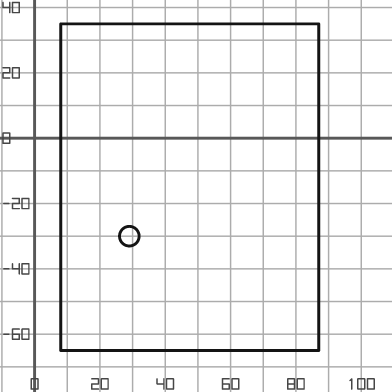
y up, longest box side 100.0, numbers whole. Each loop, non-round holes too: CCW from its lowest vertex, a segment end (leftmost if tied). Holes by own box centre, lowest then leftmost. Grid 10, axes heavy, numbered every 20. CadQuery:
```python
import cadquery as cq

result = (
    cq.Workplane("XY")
    .moveTo(8.0, -65.0)
    .lineTo(87.0, -65.0)
    .lineTo(87.0, 35.0)
    .lineTo(8.0, 35.0)
    .close()
    .moveTo(29.0, -30.0)
    .circle(3.0)
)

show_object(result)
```